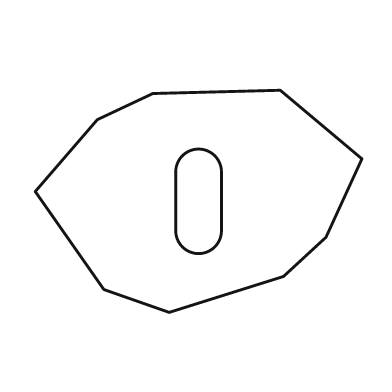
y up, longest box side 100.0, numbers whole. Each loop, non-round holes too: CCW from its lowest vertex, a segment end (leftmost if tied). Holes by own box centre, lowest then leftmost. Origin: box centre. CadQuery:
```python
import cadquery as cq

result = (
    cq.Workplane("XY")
    .moveTo(-9.0, -34.0)
    .lineTo(26.0, -23.0)
    .lineTo(39.0, -11.0)
    .lineTo(50.0, 13.0)
    .lineTo(25.0, 34.0)
    .lineTo(-14.0, 33.0)
    .lineTo(-31.0, 25.0)
    .lineTo(-50.0, 3.0)
    .lineTo(-29.0, -27.0)
    .close()
    .moveTo(-7.0, -9.0)
    .threePointArc((0.0, -16.0), (7.0, -9.0))
    .lineTo(7.0, 9.0)
    .threePointArc((0.0, 16.0), (-7.0, 9.0))
    .close()
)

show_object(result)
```